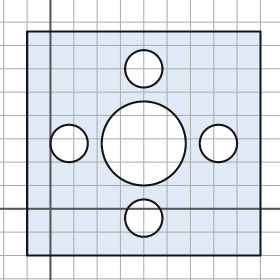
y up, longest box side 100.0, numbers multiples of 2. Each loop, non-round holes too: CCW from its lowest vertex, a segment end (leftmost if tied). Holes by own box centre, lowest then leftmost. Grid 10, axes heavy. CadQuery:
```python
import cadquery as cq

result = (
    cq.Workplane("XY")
    .moveTo(-10.0, -20.0)
    .lineTo(90.0, -20.0)
    .lineTo(90.0, 76.0)
    .lineTo(-10.0, 76.0)
    .close()
    .moveTo(40.0, -4.0)
    .circle(8.0)
    .moveTo(8.0, 28.0)
    .circle(8.0)
    .moveTo(40.0, 28.0)
    .circle(18.0)
    .moveTo(72.0, 28.0)
    .circle(8.0)
    .moveTo(40.0, 60.0)
    .circle(8.0)
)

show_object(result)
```